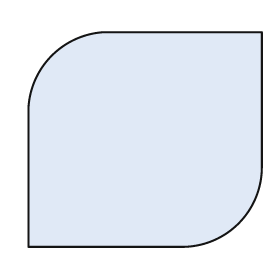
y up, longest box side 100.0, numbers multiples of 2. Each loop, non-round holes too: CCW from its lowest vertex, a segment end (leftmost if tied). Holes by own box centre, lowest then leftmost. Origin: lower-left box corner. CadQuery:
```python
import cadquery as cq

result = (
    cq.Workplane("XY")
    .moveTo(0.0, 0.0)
    .lineTo(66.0, 0.0)
    .threePointArc((90.0, 10.0), (100.0, 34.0))
    .lineTo(100.0, 92.0)
    .lineTo(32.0, 92.0)
    .threePointArc((10.0, 82.0), (0.0, 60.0))
    .close()
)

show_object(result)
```